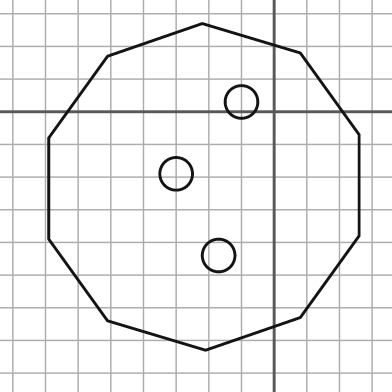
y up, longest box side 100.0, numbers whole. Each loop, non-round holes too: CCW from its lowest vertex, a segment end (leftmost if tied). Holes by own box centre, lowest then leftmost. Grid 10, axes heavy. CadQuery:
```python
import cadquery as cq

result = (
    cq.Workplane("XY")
    .moveTo(-21.0, -73.0)
    .lineTo(8.0, -63.0)
    .lineTo(26.0, -38.0)
    .lineTo(26.0, -7.0)
    .lineTo(8.0, 18.0)
    .lineTo(-22.0, 27.0)
    .lineTo(-51.0, 17.0)
    .lineTo(-69.0, -8.0)
    .lineTo(-69.0, -39.0)
    .lineTo(-51.0, -64.0)
    .close()
    .moveTo(-17.0, -44.0)
    .circle(5.0)
    .moveTo(-30.0, -19.0)
    .circle(5.0)
    .moveTo(-10.0, 3.0)
    .circle(5.0)
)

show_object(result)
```